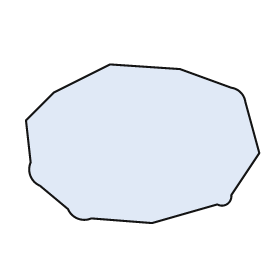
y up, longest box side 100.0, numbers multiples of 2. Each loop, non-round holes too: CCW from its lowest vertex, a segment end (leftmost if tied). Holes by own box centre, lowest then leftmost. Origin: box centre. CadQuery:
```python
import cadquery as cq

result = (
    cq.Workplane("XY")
    .moveTo(4.0, -34.0)
    .lineTo(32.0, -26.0)
    .threePointArc((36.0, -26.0), (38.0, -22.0))
    .lineTo(50.0, -4.0)
    .lineTo(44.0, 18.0)
    .threePointArc((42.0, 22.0), (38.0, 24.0))
    .lineTo(16.0, 32.0)
    .lineTo(-14.0, 34.0)
    .lineTo(-38.0, 22.0)
    .lineTo(-50.0, 10.0)
    .lineTo(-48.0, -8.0)
    .threePointArc((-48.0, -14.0), (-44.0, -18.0))
    .lineTo(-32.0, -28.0)
    .threePointArc((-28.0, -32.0), (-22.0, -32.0))
    .close()
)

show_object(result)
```